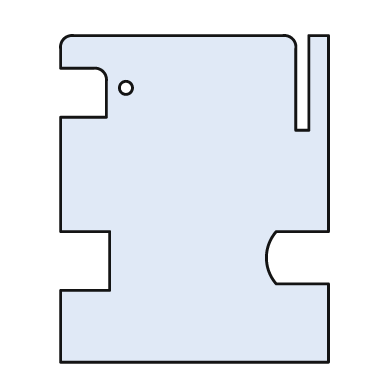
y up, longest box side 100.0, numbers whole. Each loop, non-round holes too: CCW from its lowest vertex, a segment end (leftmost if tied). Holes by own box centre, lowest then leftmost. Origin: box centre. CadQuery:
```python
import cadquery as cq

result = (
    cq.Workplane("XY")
    .moveTo(-41.0, -50.0)
    .lineTo(41.0, -50.0)
    .lineTo(41.0, -26.0)
    .lineTo(25.0, -26.0)
    .threePointArc((22.0, -18.0), (25.0, -10.0))
    .lineTo(41.0, -10.0)
    .lineTo(41.0, 50.0)
    .lineTo(35.0, 50.0)
    .lineTo(35.0, 21.0)
    .lineTo(31.0, 21.0)
    .lineTo(31.0, 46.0)
    .threePointArc((30.0, 49.0), (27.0, 50.0))
    .lineTo(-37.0, 50.0)
    .threePointArc((-40.0, 49.0), (-41.0, 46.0))
    .lineTo(-41.0, 40.0)
    .lineTo(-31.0, 40.0)
    .threePointArc((-28.0, 39.0), (-27.0, 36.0))
    .lineTo(-27.0, 25.0)
    .lineTo(-41.0, 25.0)
    .lineTo(-41.0, -10.0)
    .lineTo(-26.0, -10.0)
    .lineTo(-26.0, -28.0)
    .lineTo(-41.0, -28.0)
    .close()
    .moveTo(-21.0, 34.0)
    .circle(2.0)
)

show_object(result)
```